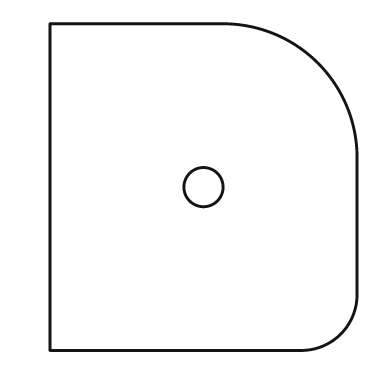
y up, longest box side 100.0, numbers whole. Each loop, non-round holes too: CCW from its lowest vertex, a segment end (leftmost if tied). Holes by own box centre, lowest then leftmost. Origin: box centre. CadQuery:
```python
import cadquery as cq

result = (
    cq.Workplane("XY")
    .moveTo(-47.0, -50.0)
    .lineTo(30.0, -50.0)
    .threePointArc((42.0, -45.0), (47.0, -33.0))
    .lineTo(47.0, 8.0)
    .threePointArc((35.0, 38.0), (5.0, 50.0))
    .lineTo(-47.0, 50.0)
    .close()
    .moveTo(0.0, 0.0)
    .circle(6.0)
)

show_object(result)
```